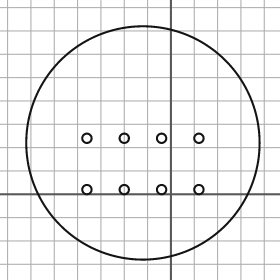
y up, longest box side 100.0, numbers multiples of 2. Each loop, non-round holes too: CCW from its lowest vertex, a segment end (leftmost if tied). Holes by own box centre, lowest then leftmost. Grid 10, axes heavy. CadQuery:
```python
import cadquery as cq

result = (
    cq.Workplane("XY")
    .moveTo(-12.0, 22.0)
    .circle(50.0)
    .moveTo(-36.0, 2.0)
    .circle(2.0)
    .moveTo(-20.0, 2.0)
    .circle(2.0)
    .moveTo(-4.0, 2.0)
    .circle(2.0)
    .moveTo(12.0, 2.0)
    .circle(2.0)
    .moveTo(-36.0, 24.0)
    .circle(2.0)
    .moveTo(-20.0, 24.0)
    .circle(2.0)
    .moveTo(-4.0, 24.0)
    .circle(2.0)
    .moveTo(12.0, 24.0)
    .circle(2.0)
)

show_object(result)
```